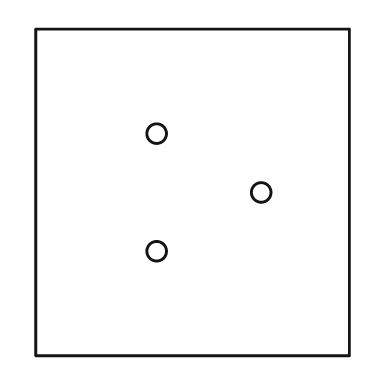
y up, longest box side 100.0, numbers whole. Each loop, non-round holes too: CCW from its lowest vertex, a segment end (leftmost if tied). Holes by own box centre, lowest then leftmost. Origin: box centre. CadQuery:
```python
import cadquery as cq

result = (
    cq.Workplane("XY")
    .moveTo(-48.0, -50.0)
    .lineTo(48.0, -50.0)
    .lineTo(48.0, 50.0)
    .lineTo(-48.0, 50.0)
    .close()
    .moveTo(-11.0, -18.0)
    .circle(3.0)
    .moveTo(21.0, 0.0)
    .circle(3.0)
    .moveTo(-11.0, 18.0)
    .circle(3.0)
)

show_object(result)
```